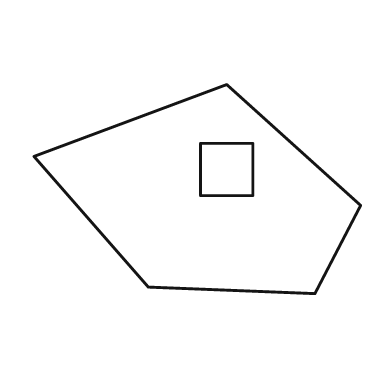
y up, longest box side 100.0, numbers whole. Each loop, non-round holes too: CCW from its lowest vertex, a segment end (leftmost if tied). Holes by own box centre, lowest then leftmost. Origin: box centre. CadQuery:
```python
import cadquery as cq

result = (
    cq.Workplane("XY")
    .moveTo(36.0, -32.0)
    .lineTo(50.0, -5.0)
    .lineTo(9.0, 32.0)
    .lineTo(-50.0, 10.0)
    .lineTo(-15.0, -30.0)
    .close()
    .moveTo(1.0, -2.0)
    .lineTo(17.0, -2.0)
    .lineTo(17.0, 14.0)
    .lineTo(1.0, 14.0)
    .close()
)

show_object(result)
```